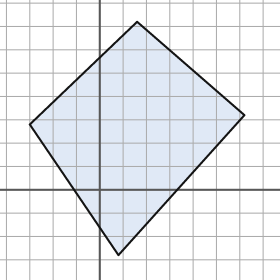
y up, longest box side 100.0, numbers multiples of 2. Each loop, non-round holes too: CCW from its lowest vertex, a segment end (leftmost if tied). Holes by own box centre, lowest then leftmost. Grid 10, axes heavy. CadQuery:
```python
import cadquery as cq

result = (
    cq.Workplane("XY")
    .moveTo(8.0, -28.0)
    .lineTo(62.0, 32.0)
    .lineTo(16.0, 72.0)
    .lineTo(-30.0, 28.0)
    .close()
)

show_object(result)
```